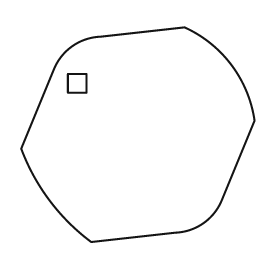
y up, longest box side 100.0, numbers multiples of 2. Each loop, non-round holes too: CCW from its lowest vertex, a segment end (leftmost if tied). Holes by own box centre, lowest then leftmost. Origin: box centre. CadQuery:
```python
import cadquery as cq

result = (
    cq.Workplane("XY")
    .moveTo(-20.0, -46.0)
    .lineTo(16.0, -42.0)
    .threePointArc((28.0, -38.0), (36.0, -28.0))
    .lineTo(50.0, 6.0)
    .threePointArc((40.0, 30.0), (20.0, 46.0))
    .lineTo(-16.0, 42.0)
    .threePointArc((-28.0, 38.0), (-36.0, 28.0))
    .lineTo(-50.0, -6.0)
    .threePointArc((-38.0, -28.0), (-20.0, -46.0))
    .close()
    .moveTo(-30.0, 18.0)
    .lineTo(-22.0, 18.0)
    .lineTo(-22.0, 26.0)
    .lineTo(-30.0, 26.0)
    .close()
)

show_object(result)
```